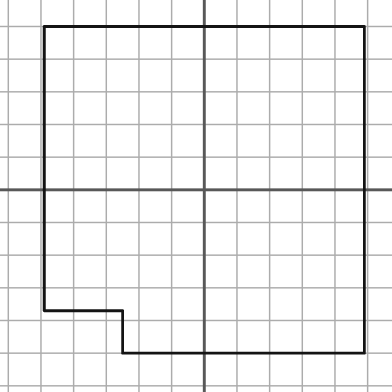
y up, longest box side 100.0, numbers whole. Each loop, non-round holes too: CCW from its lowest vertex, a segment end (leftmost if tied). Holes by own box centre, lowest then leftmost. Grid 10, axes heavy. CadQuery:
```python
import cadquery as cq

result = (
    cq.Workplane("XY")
    .moveTo(-25.0, -50.0)
    .lineTo(49.0, -50.0)
    .lineTo(49.0, 50.0)
    .lineTo(-49.0, 50.0)
    .lineTo(-49.0, -37.0)
    .lineTo(-25.0, -37.0)
    .close()
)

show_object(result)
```